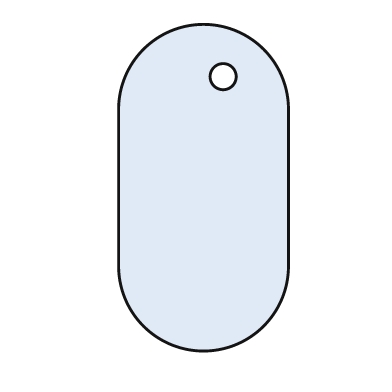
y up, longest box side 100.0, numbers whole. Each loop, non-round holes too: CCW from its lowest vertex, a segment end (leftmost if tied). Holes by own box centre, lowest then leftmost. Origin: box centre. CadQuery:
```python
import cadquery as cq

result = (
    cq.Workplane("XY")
    .moveTo(-26.0, -24.0)
    .threePointArc((0.0, -50.0), (26.0, -24.0))
    .lineTo(26.0, 24.0)
    .threePointArc((0.0, 50.0), (-26.0, 24.0))
    .close()
    .moveTo(6.0, 34.0)
    .circle(4.0)
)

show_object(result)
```